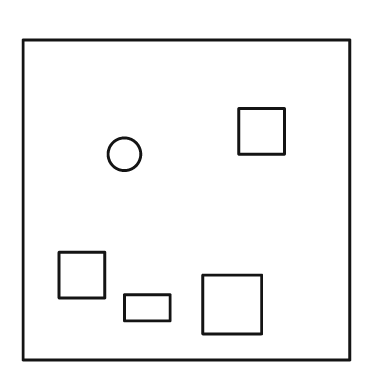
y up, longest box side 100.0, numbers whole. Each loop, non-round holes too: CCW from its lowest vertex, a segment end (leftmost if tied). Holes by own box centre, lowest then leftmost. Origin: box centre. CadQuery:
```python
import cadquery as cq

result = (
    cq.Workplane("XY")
    .moveTo(-50.0, -49.0)
    .lineTo(50.0, -49.0)
    .lineTo(50.0, 49.0)
    .lineTo(-50.0, 49.0)
    .close()
    .moveTo(-19.0, -37.0)
    .lineTo(-5.0, -37.0)
    .lineTo(-5.0, -29.0)
    .lineTo(-19.0, -29.0)
    .close()
    .moveTo(5.0, -41.0)
    .lineTo(23.0, -41.0)
    .lineTo(23.0, -23.0)
    .lineTo(5.0, -23.0)
    .close()
    .moveTo(-39.0, -30.0)
    .lineTo(-25.0, -30.0)
    .lineTo(-25.0, -16.0)
    .lineTo(-39.0, -16.0)
    .close()
    .moveTo(-19.0, 14.0)
    .circle(5.0)
    .moveTo(16.0, 14.0)
    .lineTo(30.0, 14.0)
    .lineTo(30.0, 28.0)
    .lineTo(16.0, 28.0)
    .close()
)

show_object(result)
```